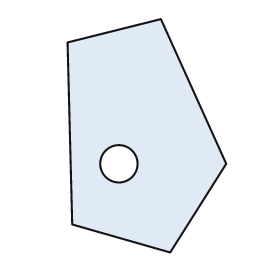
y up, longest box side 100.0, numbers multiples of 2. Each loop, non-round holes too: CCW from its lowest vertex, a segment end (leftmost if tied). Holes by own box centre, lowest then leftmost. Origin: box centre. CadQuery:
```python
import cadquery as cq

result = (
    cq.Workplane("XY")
    .moveTo(10.0, -50.0)
    .lineTo(34.0, -12.0)
    .lineTo(6.0, 50.0)
    .lineTo(-34.0, 40.0)
    .lineTo(-32.0, -38.0)
    .close()
    .moveTo(-12.0, -12.0)
    .circle(8.0)
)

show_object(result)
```